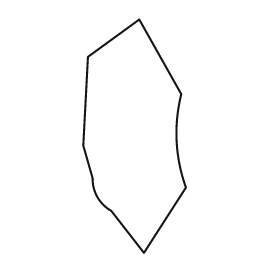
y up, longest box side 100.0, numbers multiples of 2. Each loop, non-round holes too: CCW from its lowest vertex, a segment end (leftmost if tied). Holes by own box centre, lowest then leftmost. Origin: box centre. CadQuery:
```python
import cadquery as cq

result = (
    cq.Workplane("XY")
    .moveTo(4.0, -50.0)
    .lineTo(22.0, -22.0)
    .threePointArc((18.0, -2.0), (20.0, 18.0))
    .lineTo(2.0, 50.0)
    .lineTo(-20.0, 34.0)
    .lineTo(-22.0, -4.0)
    .lineTo(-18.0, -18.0)
    .threePointArc((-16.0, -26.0), (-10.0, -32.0))
    .close()
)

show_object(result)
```